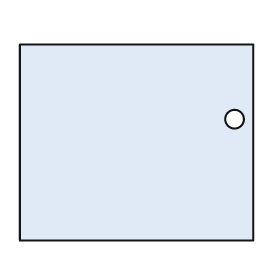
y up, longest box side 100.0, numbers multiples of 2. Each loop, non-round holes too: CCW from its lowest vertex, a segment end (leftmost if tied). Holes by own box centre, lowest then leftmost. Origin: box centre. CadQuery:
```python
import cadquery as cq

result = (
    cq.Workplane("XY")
    .moveTo(-50.0, -42.0)
    .lineTo(50.0, -42.0)
    .lineTo(50.0, 42.0)
    .lineTo(-50.0, 42.0)
    .close()
    .moveTo(42.0, 10.0)
    .circle(4.0)
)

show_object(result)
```